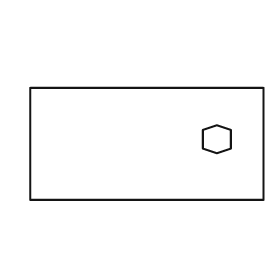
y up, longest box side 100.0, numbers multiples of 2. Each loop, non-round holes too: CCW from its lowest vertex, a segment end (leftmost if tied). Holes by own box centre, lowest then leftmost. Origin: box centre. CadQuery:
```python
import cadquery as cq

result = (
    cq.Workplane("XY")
    .moveTo(-50.0, -24.0)
    .lineTo(50.0, -24.0)
    .lineTo(50.0, 24.0)
    .lineTo(-50.0, 24.0)
    .close()
    .moveTo(30.0, -4.0)
    .lineTo(36.0, -2.0)
    .lineTo(36.0, 6.0)
    .lineTo(30.0, 8.0)
    .lineTo(24.0, 6.0)
    .lineTo(24.0, -2.0)
    .close()
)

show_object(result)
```